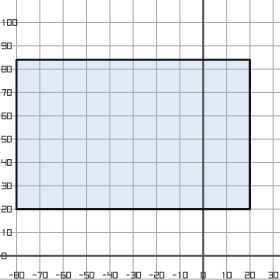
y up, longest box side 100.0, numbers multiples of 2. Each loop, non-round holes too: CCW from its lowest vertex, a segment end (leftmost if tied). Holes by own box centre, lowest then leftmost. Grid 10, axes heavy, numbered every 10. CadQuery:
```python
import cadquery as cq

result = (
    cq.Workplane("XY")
    .moveTo(-80.0, 20.0)
    .lineTo(20.0, 20.0)
    .lineTo(20.0, 84.0)
    .lineTo(-80.0, 84.0)
    .close()
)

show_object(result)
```